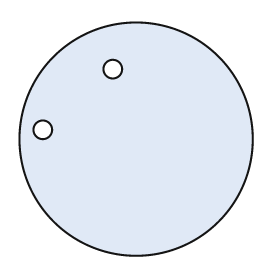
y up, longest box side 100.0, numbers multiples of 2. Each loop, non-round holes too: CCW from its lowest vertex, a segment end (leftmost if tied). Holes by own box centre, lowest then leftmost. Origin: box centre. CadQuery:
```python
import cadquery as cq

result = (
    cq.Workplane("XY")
    .moveTo(0.0, 0.0)
    .circle(50.0)
    .moveTo(-40.0, 4.0)
    .circle(4.0)
    .moveTo(-10.0, 30.0)
    .circle(4.0)
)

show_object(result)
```